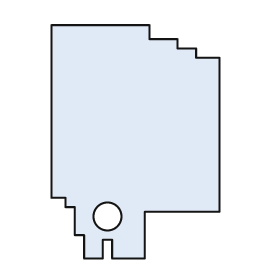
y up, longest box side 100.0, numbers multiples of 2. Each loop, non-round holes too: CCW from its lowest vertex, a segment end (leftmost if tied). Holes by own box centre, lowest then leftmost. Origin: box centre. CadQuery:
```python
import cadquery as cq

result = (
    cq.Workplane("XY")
    .moveTo(-22.0, -50.0)
    .lineTo(-14.0, -50.0)
    .lineTo(-14.0, -42.0)
    .lineTo(-10.0, -42.0)
    .lineTo(-10.0, -50.0)
    .lineTo(4.0, -50.0)
    .lineTo(4.0, -30.0)
    .lineTo(36.0, -30.0)
    .lineTo(36.0, 36.0)
    .lineTo(26.0, 36.0)
    .lineTo(26.0, 40.0)
    .lineTo(18.0, 40.0)
    .lineTo(18.0, 44.0)
    .lineTo(6.0, 44.0)
    .lineTo(6.0, 50.0)
    .lineTo(-36.0, 50.0)
    .lineTo(-36.0, -24.0)
    .lineTo(-30.0, -24.0)
    .lineTo(-30.0, -28.0)
    .lineTo(-26.0, -28.0)
    .lineTo(-26.0, -40.0)
    .lineTo(-22.0, -40.0)
    .close()
    .moveTo(-12.0, -32.0)
    .circle(6.0)
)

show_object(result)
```